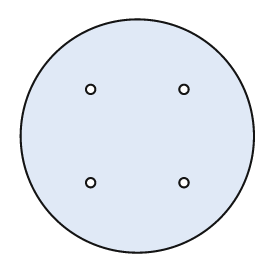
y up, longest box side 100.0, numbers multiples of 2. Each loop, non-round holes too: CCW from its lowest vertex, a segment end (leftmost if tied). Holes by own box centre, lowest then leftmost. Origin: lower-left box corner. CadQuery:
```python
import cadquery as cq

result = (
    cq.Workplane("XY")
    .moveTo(50.0, 50.0)
    .circle(50.0)
    .moveTo(30.0, 30.0)
    .circle(2.0)
    .moveTo(70.0, 30.0)
    .circle(2.0)
    .moveTo(30.0, 70.0)
    .circle(2.0)
    .moveTo(70.0, 70.0)
    .circle(2.0)
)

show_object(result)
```